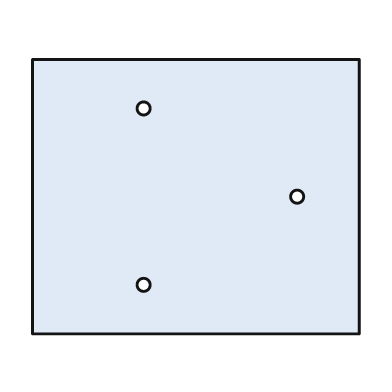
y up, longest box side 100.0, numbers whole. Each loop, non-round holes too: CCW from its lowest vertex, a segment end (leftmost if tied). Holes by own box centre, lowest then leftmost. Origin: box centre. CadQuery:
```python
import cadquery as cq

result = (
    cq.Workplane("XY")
    .moveTo(-50.0, -42.0)
    .lineTo(50.0, -42.0)
    .lineTo(50.0, 42.0)
    .lineTo(-50.0, 42.0)
    .close()
    .moveTo(-16.0, -27.0)
    .circle(2.0)
    .moveTo(31.0, 0.0)
    .circle(2.0)
    .moveTo(-16.0, 27.0)
    .circle(2.0)
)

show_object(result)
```